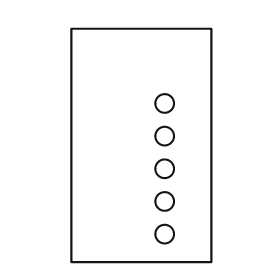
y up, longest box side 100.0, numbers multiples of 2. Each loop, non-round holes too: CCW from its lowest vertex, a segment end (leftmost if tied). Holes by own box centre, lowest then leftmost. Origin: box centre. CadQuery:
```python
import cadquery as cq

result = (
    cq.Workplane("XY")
    .moveTo(-30.0, -50.0)
    .lineTo(30.0, -50.0)
    .lineTo(30.0, 50.0)
    .lineTo(-30.0, 50.0)
    .close()
    .moveTo(10.0, -38.0)
    .circle(4.0)
    .moveTo(10.0, -24.0)
    .circle(4.0)
    .moveTo(10.0, -10.0)
    .circle(4.0)
    .moveTo(10.0, 4.0)
    .circle(4.0)
    .moveTo(10.0, 18.0)
    .circle(4.0)
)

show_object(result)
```